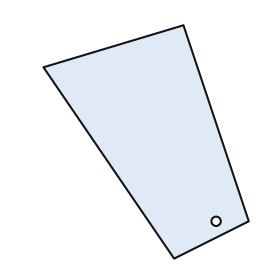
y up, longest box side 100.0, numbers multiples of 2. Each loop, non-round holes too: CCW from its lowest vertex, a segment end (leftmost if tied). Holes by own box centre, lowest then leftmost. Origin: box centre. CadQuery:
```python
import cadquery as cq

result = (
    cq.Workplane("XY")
    .moveTo(12.0, -50.0)
    .lineTo(44.0, -34.0)
    .lineTo(16.0, 50.0)
    .lineTo(-44.0, 32.0)
    .close()
    .moveTo(30.0, -34.0)
    .circle(2.0)
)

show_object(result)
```